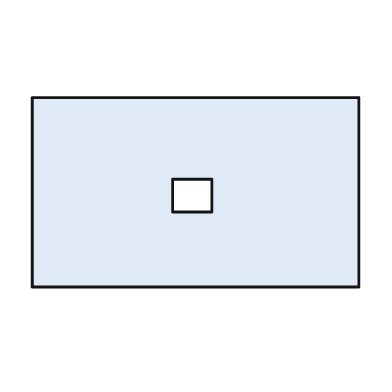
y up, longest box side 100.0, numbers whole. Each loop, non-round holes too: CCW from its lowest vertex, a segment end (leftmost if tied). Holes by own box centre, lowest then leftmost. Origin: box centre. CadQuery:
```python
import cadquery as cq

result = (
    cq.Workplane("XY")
    .moveTo(-50.0, -29.0)
    .lineTo(50.0, -29.0)
    .lineTo(50.0, 29.0)
    .lineTo(-50.0, 29.0)
    .close()
    .moveTo(-7.0, -6.0)
    .lineTo(5.0, -6.0)
    .lineTo(5.0, 4.0)
    .lineTo(-7.0, 4.0)
    .close()
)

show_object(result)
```